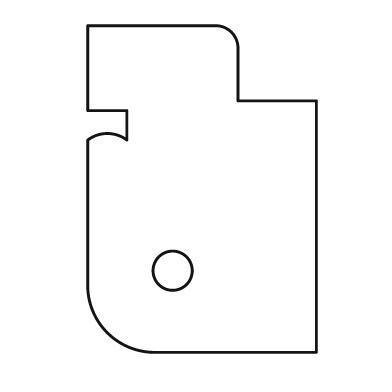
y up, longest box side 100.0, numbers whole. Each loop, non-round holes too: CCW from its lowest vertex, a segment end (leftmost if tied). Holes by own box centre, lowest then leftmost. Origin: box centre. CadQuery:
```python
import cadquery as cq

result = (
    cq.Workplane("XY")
    .moveTo(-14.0, -50.0)
    .lineTo(35.0, -50.0)
    .lineTo(35.0, 27.0)
    .lineTo(11.0, 27.0)
    .lineTo(11.0, 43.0)
    .threePointArc((9.0, 48.0), (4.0, 50.0))
    .lineTo(-35.0, 50.0)
    .lineTo(-35.0, 24.0)
    .lineTo(-23.0, 24.0)
    .lineTo(-23.0, 15.0)
    .threePointArc((-29.0, 17.0), (-35.0, 15.0))
    .lineTo(-35.0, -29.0)
    .threePointArc((-29.0, -44.0), (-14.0, -50.0))
    .close()
    .moveTo(-9.0, -25.0)
    .circle(6.0)
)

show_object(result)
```